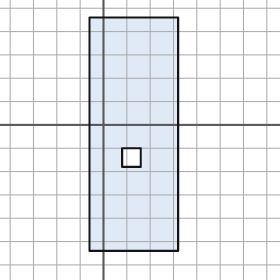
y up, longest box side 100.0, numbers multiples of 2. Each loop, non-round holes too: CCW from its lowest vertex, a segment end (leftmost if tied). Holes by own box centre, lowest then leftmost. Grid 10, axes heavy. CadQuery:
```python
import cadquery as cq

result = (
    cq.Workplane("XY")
    .moveTo(-6.0, -54.0)
    .lineTo(32.0, -54.0)
    .lineTo(32.0, 46.0)
    .lineTo(-6.0, 46.0)
    .close()
    .moveTo(8.0, -18.0)
    .lineTo(16.0, -18.0)
    .lineTo(16.0, -10.0)
    .lineTo(8.0, -10.0)
    .close()
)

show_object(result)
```